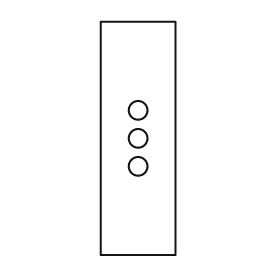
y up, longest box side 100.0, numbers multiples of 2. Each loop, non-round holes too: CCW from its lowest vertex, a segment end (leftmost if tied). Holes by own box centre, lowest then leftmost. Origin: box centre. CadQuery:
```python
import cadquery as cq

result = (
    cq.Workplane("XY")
    .moveTo(-16.0, -50.0)
    .lineTo(16.0, -50.0)
    .lineTo(16.0, 50.0)
    .lineTo(-16.0, 50.0)
    .close()
    .moveTo(0.0, -12.0)
    .circle(4.0)
    .moveTo(0.0, 0.0)
    .circle(4.0)
    .moveTo(0.0, 12.0)
    .circle(4.0)
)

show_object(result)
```